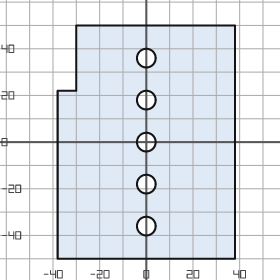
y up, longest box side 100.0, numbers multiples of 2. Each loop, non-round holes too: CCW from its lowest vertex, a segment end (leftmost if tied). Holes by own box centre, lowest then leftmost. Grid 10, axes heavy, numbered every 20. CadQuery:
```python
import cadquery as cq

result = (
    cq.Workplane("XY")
    .moveTo(-38.0, -50.0)
    .lineTo(38.0, -50.0)
    .lineTo(38.0, 50.0)
    .lineTo(-30.0, 50.0)
    .lineTo(-30.0, 22.0)
    .lineTo(-38.0, 22.0)
    .close()
    .moveTo(0.0, -36.0)
    .circle(4.0)
    .moveTo(0.0, -18.0)
    .circle(4.0)
    .moveTo(0.0, 0.0)
    .circle(4.0)
    .moveTo(0.0, 18.0)
    .circle(4.0)
    .moveTo(0.0, 36.0)
    .circle(4.0)
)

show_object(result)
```